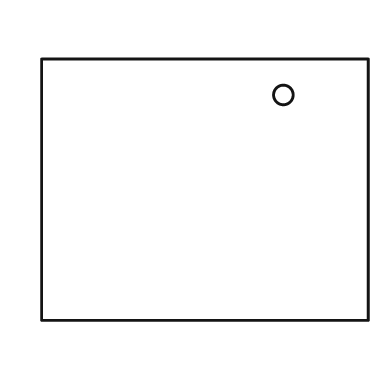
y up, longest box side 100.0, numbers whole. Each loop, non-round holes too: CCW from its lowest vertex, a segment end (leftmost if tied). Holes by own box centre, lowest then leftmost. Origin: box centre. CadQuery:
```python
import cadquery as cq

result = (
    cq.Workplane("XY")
    .moveTo(-50.0, -40.0)
    .lineTo(50.0, -40.0)
    .lineTo(50.0, 40.0)
    .lineTo(-50.0, 40.0)
    .close()
    .moveTo(24.0, 29.0)
    .circle(3.0)
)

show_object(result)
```